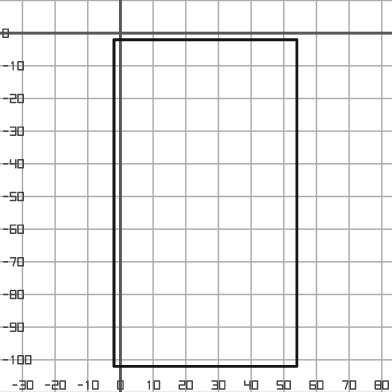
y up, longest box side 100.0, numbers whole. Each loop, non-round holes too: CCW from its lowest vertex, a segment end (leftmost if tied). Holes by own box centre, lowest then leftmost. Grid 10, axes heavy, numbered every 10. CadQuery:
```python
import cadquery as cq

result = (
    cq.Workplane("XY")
    .moveTo(-2.0, -102.0)
    .lineTo(54.0, -102.0)
    .lineTo(54.0, -2.0)
    .lineTo(-2.0, -2.0)
    .close()
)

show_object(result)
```